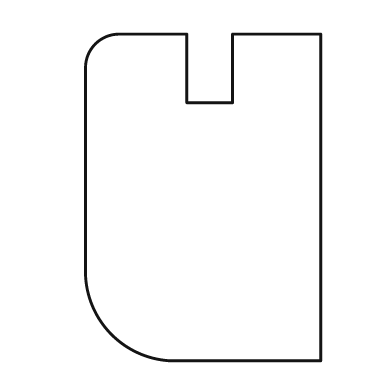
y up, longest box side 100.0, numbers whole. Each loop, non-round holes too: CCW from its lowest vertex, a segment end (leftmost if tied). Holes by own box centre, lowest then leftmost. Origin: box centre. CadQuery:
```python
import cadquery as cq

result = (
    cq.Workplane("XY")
    .moveTo(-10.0, -50.0)
    .lineTo(36.0, -50.0)
    .lineTo(36.0, 50.0)
    .lineTo(9.0, 50.0)
    .lineTo(9.0, 29.0)
    .lineTo(-5.0, 29.0)
    .lineTo(-5.0, 50.0)
    .lineTo(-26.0, 50.0)
    .threePointArc((-33.0, 47.0), (-36.0, 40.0))
    .lineTo(-36.0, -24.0)
    .threePointArc((-28.0, -42.0), (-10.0, -50.0))
    .close()
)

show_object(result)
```